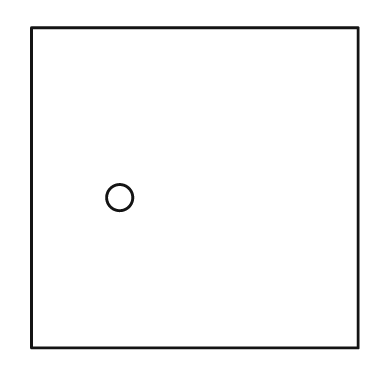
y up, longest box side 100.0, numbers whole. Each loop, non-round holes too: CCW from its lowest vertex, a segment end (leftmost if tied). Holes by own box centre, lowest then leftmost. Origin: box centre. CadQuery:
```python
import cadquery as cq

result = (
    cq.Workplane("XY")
    .moveTo(-50.0, -49.0)
    .lineTo(50.0, -49.0)
    .lineTo(50.0, 49.0)
    .lineTo(-50.0, 49.0)
    .close()
    .moveTo(-23.0, -3.0)
    .circle(4.0)
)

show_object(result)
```